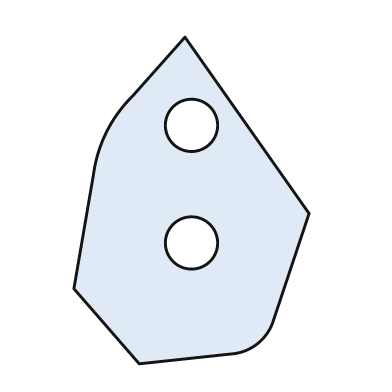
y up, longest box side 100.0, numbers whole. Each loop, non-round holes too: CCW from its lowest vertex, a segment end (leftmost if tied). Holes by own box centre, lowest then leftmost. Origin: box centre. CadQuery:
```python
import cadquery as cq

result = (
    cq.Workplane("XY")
    .moveTo(-16.0, -50.0)
    .lineTo(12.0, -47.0)
    .threePointArc((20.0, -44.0), (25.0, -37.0))
    .lineTo(36.0, -4.0)
    .lineTo(-2.0, 50.0)
    .lineTo(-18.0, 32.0)
    .threePointArc((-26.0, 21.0), (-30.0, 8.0))
    .lineTo(-36.0, -27.0)
    .close()
    .moveTo(0.0, -13.0)
    .circle(8.0)
    .moveTo(0.0, 23.0)
    .circle(8.0)
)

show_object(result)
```